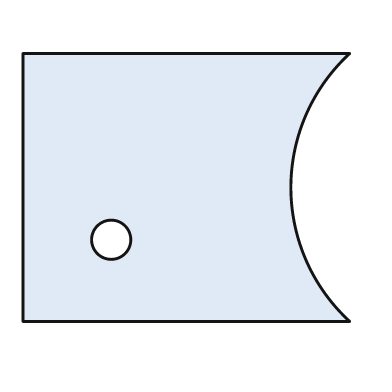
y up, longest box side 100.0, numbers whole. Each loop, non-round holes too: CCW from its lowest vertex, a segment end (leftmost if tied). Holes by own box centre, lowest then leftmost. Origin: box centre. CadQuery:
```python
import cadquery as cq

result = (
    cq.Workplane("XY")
    .moveTo(-50.0, -41.0)
    .lineTo(50.0, -41.0)
    .threePointArc((32.0, 0.0), (50.0, 41.0))
    .lineTo(-50.0, 41.0)
    .close()
    .moveTo(-23.0, -16.0)
    .circle(6.0)
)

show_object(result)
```